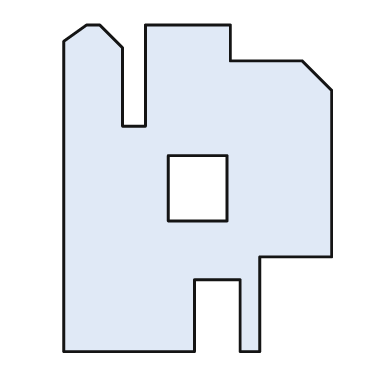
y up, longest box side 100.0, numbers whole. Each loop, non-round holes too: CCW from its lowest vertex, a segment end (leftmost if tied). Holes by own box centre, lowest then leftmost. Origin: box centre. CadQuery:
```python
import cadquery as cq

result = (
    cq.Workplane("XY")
    .moveTo(-41.0, -50.0)
    .lineTo(-1.0, -50.0)
    .lineTo(-1.0, -28.0)
    .lineTo(13.0, -28.0)
    .lineTo(13.0, -50.0)
    .lineTo(19.0, -50.0)
    .lineTo(19.0, -21.0)
    .lineTo(41.0, -21.0)
    .lineTo(41.0, 30.0)
    .lineTo(32.0, 39.0)
    .lineTo(10.0, 39.0)
    .lineTo(10.0, 50.0)
    .lineTo(-16.0, 50.0)
    .lineTo(-16.0, 19.0)
    .lineTo(-23.0, 19.0)
    .lineTo(-23.0, 43.0)
    .lineTo(-30.0, 50.0)
    .lineTo(-34.0, 50.0)
    .lineTo(-41.0, 45.0)
    .close()
    .moveTo(-9.0, -10.0)
    .lineTo(9.0, -10.0)
    .lineTo(9.0, 10.0)
    .lineTo(-9.0, 10.0)
    .close()
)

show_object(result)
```